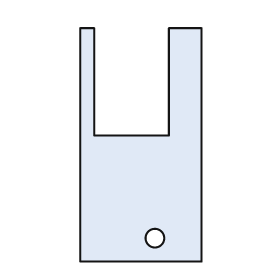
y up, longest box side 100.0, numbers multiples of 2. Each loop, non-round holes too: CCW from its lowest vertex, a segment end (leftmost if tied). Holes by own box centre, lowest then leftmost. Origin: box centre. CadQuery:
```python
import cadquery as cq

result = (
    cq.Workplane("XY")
    .moveTo(-26.0, -50.0)
    .lineTo(26.0, -50.0)
    .lineTo(26.0, 50.0)
    .lineTo(12.0, 50.0)
    .lineTo(12.0, 4.0)
    .lineTo(-20.0, 4.0)
    .lineTo(-20.0, 50.0)
    .lineTo(-26.0, 50.0)
    .close()
    .moveTo(6.0, -40.0)
    .circle(4.0)
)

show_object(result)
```